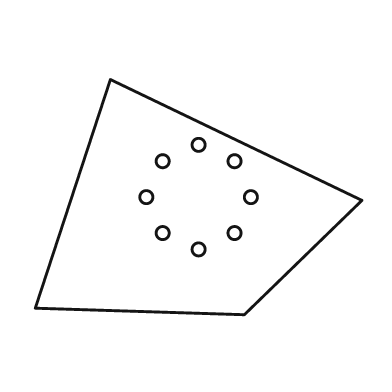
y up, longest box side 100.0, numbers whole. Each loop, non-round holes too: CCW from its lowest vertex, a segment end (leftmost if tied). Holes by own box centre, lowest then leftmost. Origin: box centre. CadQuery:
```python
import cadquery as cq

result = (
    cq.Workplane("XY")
    .moveTo(14.0, -36.0)
    .lineTo(50.0, -1.0)
    .lineTo(-27.0, 36.0)
    .lineTo(-50.0, -34.0)
    .close()
    .moveTo(0.0, -16.0)
    .circle(2.0)
    .moveTo(-11.0, -11.0)
    .circle(2.0)
    .moveTo(11.0, -11.0)
    .circle(2.0)
    .moveTo(-16.0, 0.0)
    .circle(2.0)
    .moveTo(16.0, 0.0)
    .circle(2.0)
    .moveTo(-11.0, 11.0)
    .circle(2.0)
    .moveTo(11.0, 11.0)
    .circle(2.0)
    .moveTo(0.0, 16.0)
    .circle(2.0)
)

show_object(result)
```